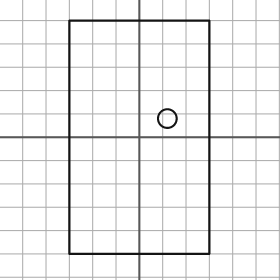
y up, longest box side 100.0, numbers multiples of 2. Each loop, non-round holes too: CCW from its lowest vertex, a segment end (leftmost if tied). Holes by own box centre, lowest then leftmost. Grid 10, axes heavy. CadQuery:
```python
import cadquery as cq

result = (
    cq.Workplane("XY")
    .moveTo(-30.0, -50.0)
    .lineTo(30.0, -50.0)
    .lineTo(30.0, 50.0)
    .lineTo(-30.0, 50.0)
    .close()
    .moveTo(12.0, 8.0)
    .circle(4.0)
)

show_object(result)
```